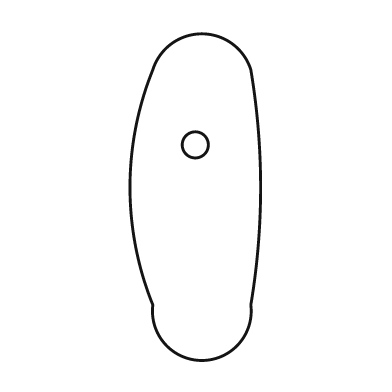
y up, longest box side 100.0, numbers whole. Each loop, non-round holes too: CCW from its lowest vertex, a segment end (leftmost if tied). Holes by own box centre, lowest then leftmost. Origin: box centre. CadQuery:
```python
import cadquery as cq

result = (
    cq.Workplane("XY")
    .moveTo(-13.0, -33.0)
    .threePointArc((2.0, -50.0), (17.0, -33.0))
    .threePointArc((20.0, 3.0), (17.0, 39.0))
    .threePointArc((2.0, 50.0), (-13.0, 39.0))
    .threePointArc((-20.0, 3.0), (-13.0, -33.0))
    .close()
    .moveTo(0.0, 16.0)
    .circle(4.0)
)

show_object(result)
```